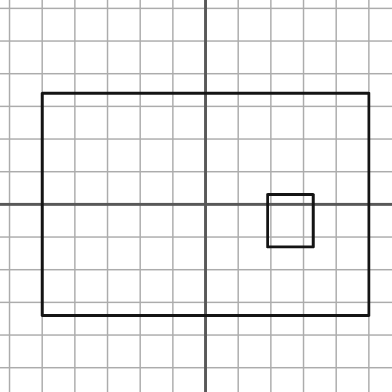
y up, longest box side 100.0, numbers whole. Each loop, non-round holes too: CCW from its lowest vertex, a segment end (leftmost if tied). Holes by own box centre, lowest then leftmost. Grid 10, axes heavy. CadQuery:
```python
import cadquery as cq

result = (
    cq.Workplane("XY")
    .moveTo(-50.0, -34.0)
    .lineTo(50.0, -34.0)
    .lineTo(50.0, 34.0)
    .lineTo(-50.0, 34.0)
    .close()
    .moveTo(19.0, -13.0)
    .lineTo(33.0, -13.0)
    .lineTo(33.0, 3.0)
    .lineTo(19.0, 3.0)
    .close()
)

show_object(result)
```